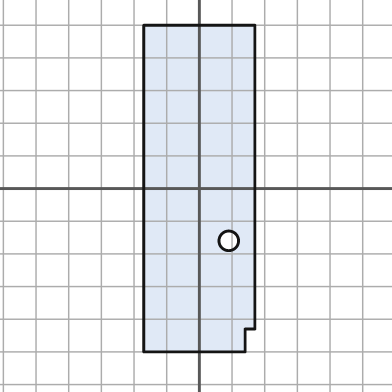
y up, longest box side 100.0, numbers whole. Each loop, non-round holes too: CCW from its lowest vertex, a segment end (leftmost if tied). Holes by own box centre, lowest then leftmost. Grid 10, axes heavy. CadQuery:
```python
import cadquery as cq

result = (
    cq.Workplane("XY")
    .moveTo(-17.0, -50.0)
    .lineTo(14.0, -50.0)
    .lineTo(14.0, -43.0)
    .lineTo(17.0, -43.0)
    .lineTo(17.0, 50.0)
    .lineTo(-17.0, 50.0)
    .close()
    .moveTo(9.0, -16.0)
    .circle(3.0)
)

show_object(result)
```